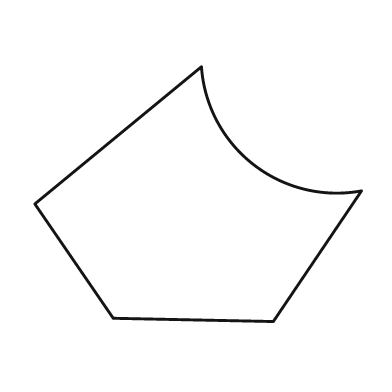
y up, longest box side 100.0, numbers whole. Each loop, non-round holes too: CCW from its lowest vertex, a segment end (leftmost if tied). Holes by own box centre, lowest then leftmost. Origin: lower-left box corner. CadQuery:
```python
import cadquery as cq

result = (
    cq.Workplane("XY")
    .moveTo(73.0, 0.0)
    .lineTo(100.0, 40.0)
    .threePointArc((67.0, 48.0), (51.0, 78.0))
    .lineTo(0.0, 36.0)
    .lineTo(24.0, 1.0)
    .close()
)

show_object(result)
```